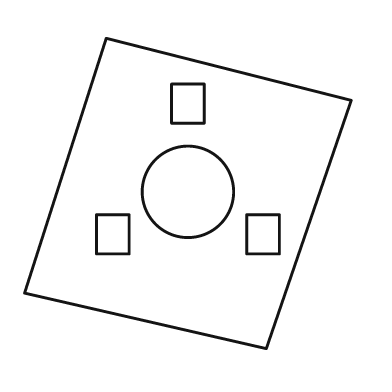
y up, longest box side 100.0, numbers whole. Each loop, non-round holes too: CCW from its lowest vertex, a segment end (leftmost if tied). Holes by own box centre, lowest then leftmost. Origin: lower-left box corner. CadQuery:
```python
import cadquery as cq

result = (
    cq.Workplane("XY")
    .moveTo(74.0, 0.0)
    .lineTo(100.0, 76.0)
    .lineTo(25.0, 95.0)
    .lineTo(0.0, 17.0)
    .close()
    .moveTo(22.0, 29.0)
    .lineTo(32.0, 29.0)
    .lineTo(32.0, 41.0)
    .lineTo(22.0, 41.0)
    .close()
    .moveTo(68.0, 29.0)
    .lineTo(78.0, 29.0)
    .lineTo(78.0, 41.0)
    .lineTo(68.0, 41.0)
    .close()
    .moveTo(50.0, 48.0)
    .circle(14.0)
    .moveTo(45.0, 69.0)
    .lineTo(55.0, 69.0)
    .lineTo(55.0, 81.0)
    .lineTo(45.0, 81.0)
    .close()
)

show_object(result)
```